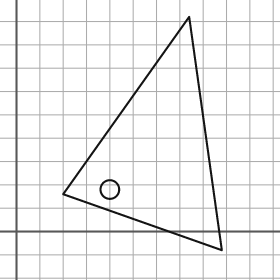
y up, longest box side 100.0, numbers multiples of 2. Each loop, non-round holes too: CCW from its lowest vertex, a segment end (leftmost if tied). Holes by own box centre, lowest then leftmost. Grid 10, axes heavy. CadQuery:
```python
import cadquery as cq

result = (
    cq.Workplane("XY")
    .moveTo(88.0, -8.0)
    .lineTo(74.0, 92.0)
    .lineTo(20.0, 16.0)
    .close()
    .moveTo(40.0, 18.0)
    .circle(4.0)
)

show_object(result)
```